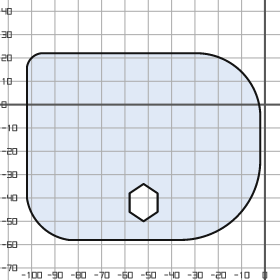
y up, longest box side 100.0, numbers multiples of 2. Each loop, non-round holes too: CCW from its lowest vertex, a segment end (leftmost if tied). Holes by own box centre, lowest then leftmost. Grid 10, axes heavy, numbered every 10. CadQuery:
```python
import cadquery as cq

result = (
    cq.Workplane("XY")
    .moveTo(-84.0, -58.0)
    .lineTo(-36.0, -58.0)
    .threePointArc((-12.0, -48.0), (-2.0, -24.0))
    .lineTo(-2.0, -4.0)
    .threePointArc((-10.0, 14.0), (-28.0, 22.0))
    .lineTo(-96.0, 22.0)
    .threePointArc((-100.0, 20.0), (-102.0, 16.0))
    .lineTo(-102.0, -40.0)
    .threePointArc((-96.0, -52.0), (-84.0, -58.0))
    .close()
    .moveTo(-52.0, -50.0)
    .lineTo(-46.0, -46.0)
    .lineTo(-46.0, -38.0)
    .lineTo(-52.0, -34.0)
    .lineTo(-58.0, -38.0)
    .lineTo(-58.0, -46.0)
    .close()
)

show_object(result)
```